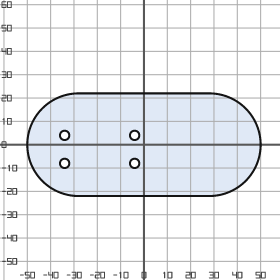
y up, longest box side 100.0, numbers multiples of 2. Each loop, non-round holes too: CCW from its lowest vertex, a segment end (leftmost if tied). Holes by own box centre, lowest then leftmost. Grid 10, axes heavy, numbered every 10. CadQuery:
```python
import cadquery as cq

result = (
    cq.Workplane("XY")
    .moveTo(-28.0, -22.0)
    .lineTo(28.0, -22.0)
    .threePointArc((50.0, 0.0), (28.0, 22.0))
    .lineTo(-28.0, 22.0)
    .threePointArc((-50.0, 0.0), (-28.0, -22.0))
    .close()
    .moveTo(-34.0, -8.0)
    .circle(2.0)
    .moveTo(-4.0, -8.0)
    .circle(2.0)
    .moveTo(-34.0, 4.0)
    .circle(2.0)
    .moveTo(-4.0, 4.0)
    .circle(2.0)
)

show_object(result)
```